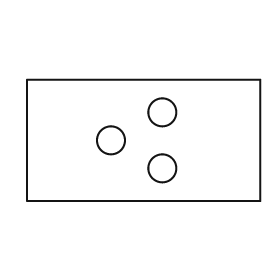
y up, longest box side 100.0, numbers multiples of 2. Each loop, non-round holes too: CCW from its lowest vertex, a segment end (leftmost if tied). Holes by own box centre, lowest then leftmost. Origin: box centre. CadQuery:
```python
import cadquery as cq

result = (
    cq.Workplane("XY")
    .moveTo(-50.0, -26.0)
    .lineTo(50.0, -26.0)
    .lineTo(50.0, 26.0)
    .lineTo(-50.0, 26.0)
    .close()
    .moveTo(8.0, -12.0)
    .circle(6.0)
    .moveTo(-14.0, 0.0)
    .circle(6.0)
    .moveTo(8.0, 12.0)
    .circle(6.0)
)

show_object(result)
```